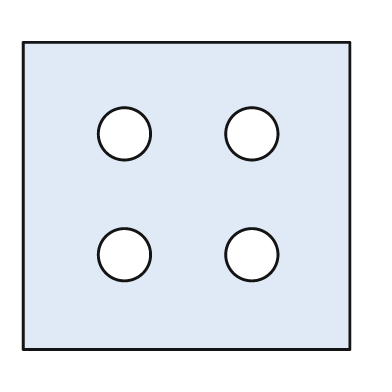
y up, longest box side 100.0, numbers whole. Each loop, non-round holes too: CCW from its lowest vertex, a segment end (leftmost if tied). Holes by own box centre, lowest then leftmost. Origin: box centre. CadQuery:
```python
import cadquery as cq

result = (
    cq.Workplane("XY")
    .moveTo(-50.0, -47.0)
    .lineTo(50.0, -47.0)
    .lineTo(50.0, 47.0)
    .lineTo(-50.0, 47.0)
    .close()
    .moveTo(-19.0, -18.0)
    .circle(8.0)
    .moveTo(20.0, -18.0)
    .circle(8.0)
    .moveTo(-19.0, 19.0)
    .circle(8.0)
    .moveTo(20.0, 19.0)
    .circle(8.0)
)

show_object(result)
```